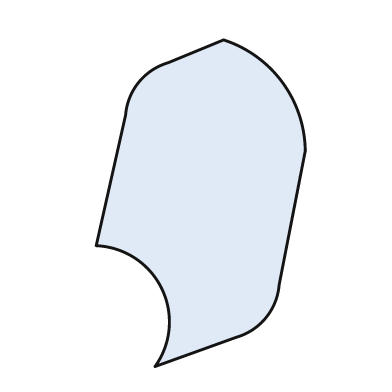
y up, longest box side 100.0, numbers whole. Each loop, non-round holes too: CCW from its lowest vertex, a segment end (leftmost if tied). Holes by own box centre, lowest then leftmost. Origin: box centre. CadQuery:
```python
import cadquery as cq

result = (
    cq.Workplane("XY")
    .moveTo(-14.0, -50.0)
    .lineTo(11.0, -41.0)
    .threePointArc((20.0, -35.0), (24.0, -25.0))
    .lineTo(32.0, 16.0)
    .threePointArc((25.0, 37.0), (7.0, 50.0))
    .lineTo(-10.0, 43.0)
    .threePointArc((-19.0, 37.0), (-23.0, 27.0))
    .lineTo(-32.0, -13.0)
    .threePointArc((-12.0, -26.0), (-14.0, -50.0))
    .close()
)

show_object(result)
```